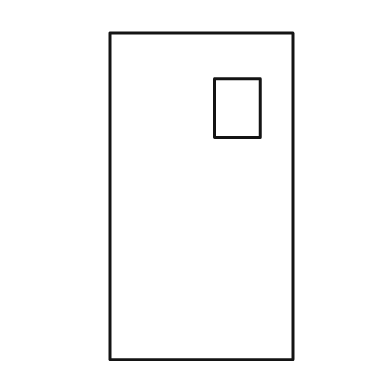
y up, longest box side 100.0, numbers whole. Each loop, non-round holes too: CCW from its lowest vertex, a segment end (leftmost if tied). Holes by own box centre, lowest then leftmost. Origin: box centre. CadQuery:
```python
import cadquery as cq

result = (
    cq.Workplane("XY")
    .moveTo(-28.0, -50.0)
    .lineTo(28.0, -50.0)
    .lineTo(28.0, 50.0)
    .lineTo(-28.0, 50.0)
    .close()
    .moveTo(4.0, 18.0)
    .lineTo(18.0, 18.0)
    .lineTo(18.0, 36.0)
    .lineTo(4.0, 36.0)
    .close()
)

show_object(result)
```